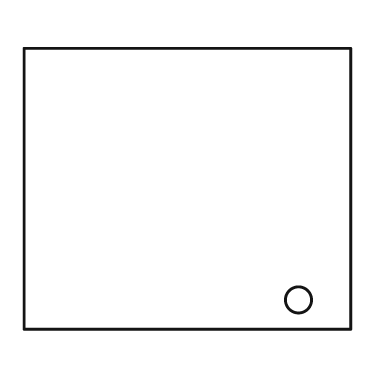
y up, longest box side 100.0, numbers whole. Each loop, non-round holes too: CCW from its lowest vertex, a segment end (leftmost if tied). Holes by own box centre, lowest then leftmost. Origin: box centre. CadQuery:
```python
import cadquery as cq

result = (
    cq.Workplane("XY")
    .moveTo(-50.0, -43.0)
    .lineTo(50.0, -43.0)
    .lineTo(50.0, 43.0)
    .lineTo(-50.0, 43.0)
    .close()
    .moveTo(34.0, -34.0)
    .circle(4.0)
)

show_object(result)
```